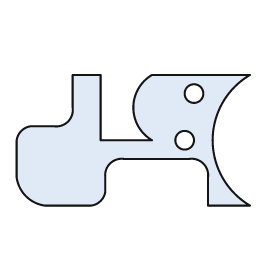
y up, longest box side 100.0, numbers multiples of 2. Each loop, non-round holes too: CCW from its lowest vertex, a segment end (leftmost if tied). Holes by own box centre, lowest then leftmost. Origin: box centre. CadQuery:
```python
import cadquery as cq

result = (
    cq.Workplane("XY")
    .moveTo(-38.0, -28.0)
    .lineTo(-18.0, -28.0)
    .threePointArc((-14.0, -26.0), (-12.0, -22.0))
    .lineTo(-12.0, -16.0)
    .threePointArc((-10.0, -10.0), (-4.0, -8.0))
    .lineTo(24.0, -8.0)
    .threePointArc((30.0, -10.0), (32.0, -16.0))
    .lineTo(32.0, -28.0)
    .lineTo(50.0, -28.0)
    .threePointArc((34.0, 0.0), (50.0, 28.0))
    .lineTo(8.0, 28.0)
    .threePointArc((0.0, 14.0), (8.0, 0.0))
    .lineTo(-14.0, 0.0)
    .lineTo(-14.0, 28.0)
    .lineTo(-26.0, 28.0)
    .lineTo(-26.0, 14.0)
    .threePointArc((-28.0, 8.0), (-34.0, 6.0))
    .lineTo(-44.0, 6.0)
    .threePointArc((-48.0, 4.0), (-50.0, 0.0))
    .lineTo(-50.0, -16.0)
    .threePointArc((-46.0, -24.0), (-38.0, -28.0))
    .close()
    .moveTo(22.0, 0.0)
    .circle(4.0)
    .moveTo(26.0, 20.0)
    .circle(4.0)
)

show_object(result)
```